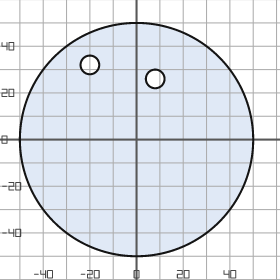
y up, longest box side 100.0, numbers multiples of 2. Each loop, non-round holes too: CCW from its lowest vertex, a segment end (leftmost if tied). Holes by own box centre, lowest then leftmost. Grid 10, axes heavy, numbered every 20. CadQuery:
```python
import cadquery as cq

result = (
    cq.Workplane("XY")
    .moveTo(0.0, 0.0)
    .circle(50.0)
    .moveTo(8.0, 26.0)
    .circle(4.0)
    .moveTo(-20.0, 32.0)
    .circle(4.0)
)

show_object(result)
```